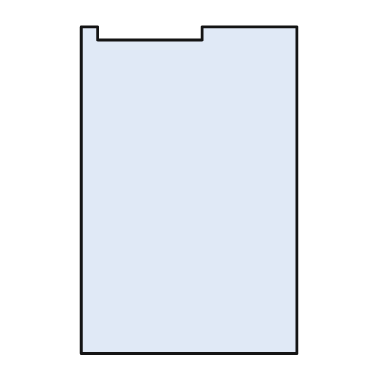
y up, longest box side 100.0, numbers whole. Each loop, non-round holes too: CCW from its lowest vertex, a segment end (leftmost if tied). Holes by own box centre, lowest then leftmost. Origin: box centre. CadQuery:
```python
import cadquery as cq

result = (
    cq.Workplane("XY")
    .moveTo(-33.0, -50.0)
    .lineTo(33.0, -50.0)
    .lineTo(33.0, 50.0)
    .lineTo(4.0, 50.0)
    .lineTo(4.0, 46.0)
    .lineTo(-28.0, 46.0)
    .lineTo(-28.0, 50.0)
    .lineTo(-33.0, 50.0)
    .close()
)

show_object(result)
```